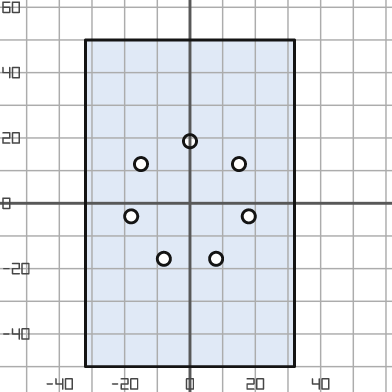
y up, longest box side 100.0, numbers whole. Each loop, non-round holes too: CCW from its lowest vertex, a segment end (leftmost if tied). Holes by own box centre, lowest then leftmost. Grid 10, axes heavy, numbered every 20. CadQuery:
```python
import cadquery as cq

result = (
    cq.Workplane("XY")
    .moveTo(-32.0, -50.0)
    .lineTo(32.0, -50.0)
    .lineTo(32.0, 50.0)
    .lineTo(-32.0, 50.0)
    .close()
    .moveTo(-8.0, -17.0)
    .circle(2.0)
    .moveTo(8.0, -17.0)
    .circle(2.0)
    .moveTo(-18.0, -4.0)
    .circle(2.0)
    .moveTo(18.0, -4.0)
    .circle(2.0)
    .moveTo(-15.0, 12.0)
    .circle(2.0)
    .moveTo(15.0, 12.0)
    .circle(2.0)
    .moveTo(0.0, 19.0)
    .circle(2.0)
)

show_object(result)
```